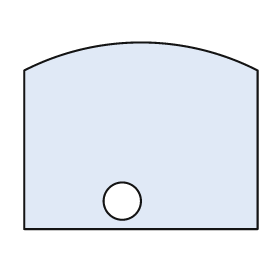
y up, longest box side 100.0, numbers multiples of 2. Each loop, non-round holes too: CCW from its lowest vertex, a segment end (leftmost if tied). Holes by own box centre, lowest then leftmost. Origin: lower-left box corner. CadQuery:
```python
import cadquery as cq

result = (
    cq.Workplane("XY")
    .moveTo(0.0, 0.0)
    .lineTo(100.0, 0.0)
    .lineTo(100.0, 68.0)
    .threePointArc((50.0, 80.0), (0.0, 68.0))
    .close()
    .moveTo(42.0, 12.0)
    .circle(8.0)
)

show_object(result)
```